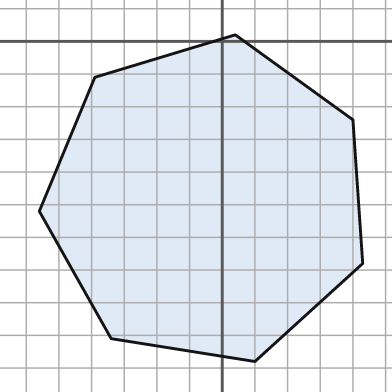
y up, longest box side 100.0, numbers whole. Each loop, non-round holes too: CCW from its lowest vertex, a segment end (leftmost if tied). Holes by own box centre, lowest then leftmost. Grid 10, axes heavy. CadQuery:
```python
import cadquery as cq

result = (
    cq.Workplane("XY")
    .moveTo(10.0, -98.0)
    .lineTo(43.0, -68.0)
    .lineTo(40.0, -24.0)
    .lineTo(4.0, 2.0)
    .lineTo(-39.0, -11.0)
    .lineTo(-56.0, -52.0)
    .lineTo(-34.0, -91.0)
    .close()
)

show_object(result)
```